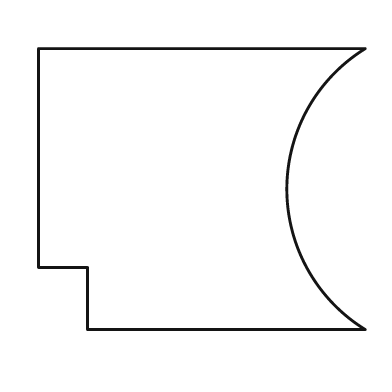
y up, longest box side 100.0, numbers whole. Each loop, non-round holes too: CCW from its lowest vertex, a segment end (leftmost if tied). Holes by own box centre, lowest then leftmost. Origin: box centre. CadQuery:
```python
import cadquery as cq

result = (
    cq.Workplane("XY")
    .moveTo(-35.0, -43.0)
    .lineTo(50.0, -43.0)
    .threePointArc((26.0, 0.0), (50.0, 43.0))
    .lineTo(-50.0, 43.0)
    .lineTo(-50.0, -24.0)
    .lineTo(-35.0, -24.0)
    .close()
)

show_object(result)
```